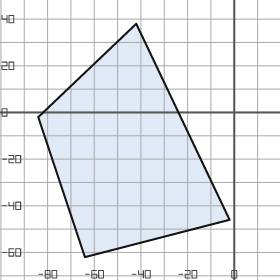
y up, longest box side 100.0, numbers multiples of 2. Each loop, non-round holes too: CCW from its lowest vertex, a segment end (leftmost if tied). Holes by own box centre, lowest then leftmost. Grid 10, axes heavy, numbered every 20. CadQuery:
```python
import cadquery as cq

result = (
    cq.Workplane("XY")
    .moveTo(-64.0, -62.0)
    .lineTo(-2.0, -46.0)
    .lineTo(-42.0, 38.0)
    .lineTo(-84.0, -2.0)
    .close()
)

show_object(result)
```